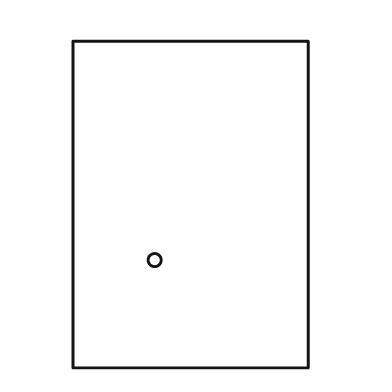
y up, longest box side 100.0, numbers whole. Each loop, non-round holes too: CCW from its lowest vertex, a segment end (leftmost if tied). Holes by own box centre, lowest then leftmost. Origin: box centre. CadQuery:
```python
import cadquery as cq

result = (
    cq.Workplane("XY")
    .moveTo(-36.0, -50.0)
    .lineTo(36.0, -50.0)
    .lineTo(36.0, 50.0)
    .lineTo(-36.0, 50.0)
    .close()
    .moveTo(-11.0, -17.0)
    .circle(2.0)
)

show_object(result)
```